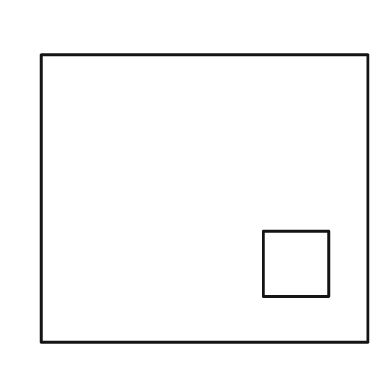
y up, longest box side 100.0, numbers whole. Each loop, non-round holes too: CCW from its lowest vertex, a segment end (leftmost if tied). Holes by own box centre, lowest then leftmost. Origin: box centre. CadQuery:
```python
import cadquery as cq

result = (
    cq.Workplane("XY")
    .moveTo(-50.0, -44.0)
    .lineTo(50.0, -44.0)
    .lineTo(50.0, 44.0)
    .lineTo(-50.0, 44.0)
    .close()
    .moveTo(18.0, -30.0)
    .lineTo(38.0, -30.0)
    .lineTo(38.0, -10.0)
    .lineTo(18.0, -10.0)
    .close()
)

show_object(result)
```